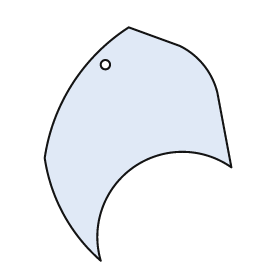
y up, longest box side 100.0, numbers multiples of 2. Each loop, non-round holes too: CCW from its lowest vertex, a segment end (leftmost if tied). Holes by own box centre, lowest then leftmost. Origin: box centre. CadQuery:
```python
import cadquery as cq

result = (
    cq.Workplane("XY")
    .moveTo(-16.0, -50.0)
    .threePointArc((-2.0, -10.0), (40.0, -10.0))
    .lineTo(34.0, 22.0)
    .threePointArc((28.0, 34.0), (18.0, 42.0))
    .lineTo(-4.0, 50.0)
    .threePointArc((-28.0, 26.0), (-40.0, -6.0))
    .threePointArc((-32.0, -30.0), (-16.0, -50.0))
    .close()
    .moveTo(-14.0, 34.0)
    .circle(2.0)
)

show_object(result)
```